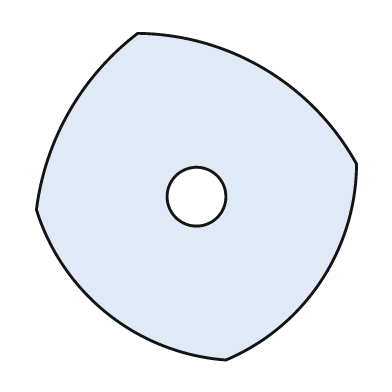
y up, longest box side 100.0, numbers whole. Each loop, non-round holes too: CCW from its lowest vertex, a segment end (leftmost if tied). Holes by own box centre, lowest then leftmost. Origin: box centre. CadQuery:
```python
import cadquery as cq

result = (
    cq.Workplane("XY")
    .moveTo(9.0, -50.0)
    .threePointArc((38.0, -26.0), (49.0, 10.0))
    .threePointArc((21.0, 39.0), (-18.0, 50.0))
    .threePointArc((-39.0, 26.0), (-49.0, -4.0))
    .threePointArc((-27.0, -36.0), (9.0, -50.0))
    .close()
    .moveTo(0.0, 0.0)
    .circle(9.0)
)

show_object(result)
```